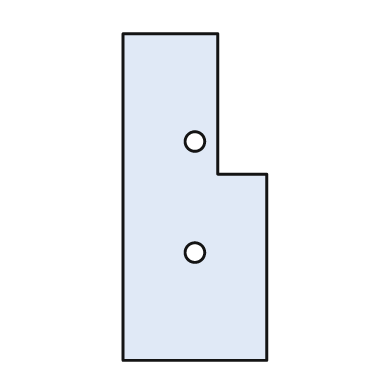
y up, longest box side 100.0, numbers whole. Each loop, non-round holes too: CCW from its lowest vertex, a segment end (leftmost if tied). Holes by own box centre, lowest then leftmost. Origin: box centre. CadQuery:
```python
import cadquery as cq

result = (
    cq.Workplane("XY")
    .moveTo(-22.0, -50.0)
    .lineTo(22.0, -50.0)
    .lineTo(22.0, 7.0)
    .lineTo(7.0, 7.0)
    .lineTo(7.0, 50.0)
    .lineTo(-22.0, 50.0)
    .close()
    .moveTo(0.0, -17.0)
    .circle(3.0)
    .moveTo(0.0, 17.0)
    .circle(3.0)
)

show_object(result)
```